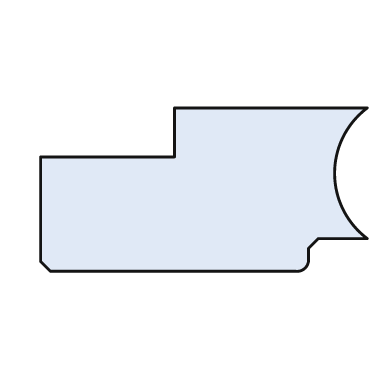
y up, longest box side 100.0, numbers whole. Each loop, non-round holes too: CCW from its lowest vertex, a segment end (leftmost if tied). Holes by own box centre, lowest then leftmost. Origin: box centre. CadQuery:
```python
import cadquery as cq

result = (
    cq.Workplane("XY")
    .moveTo(-47.0, -25.0)
    .lineTo(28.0, -25.0)
    .threePointArc((31.0, -24.0), (32.0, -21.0))
    .lineTo(32.0, -18.0)
    .lineTo(35.0, -15.0)
    .lineTo(50.0, -15.0)
    .threePointArc((40.0, 5.0), (50.0, 25.0))
    .lineTo(-9.0, 25.0)
    .lineTo(-9.0, 10.0)
    .lineTo(-50.0, 10.0)
    .lineTo(-50.0, -22.0)
    .close()
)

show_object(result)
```